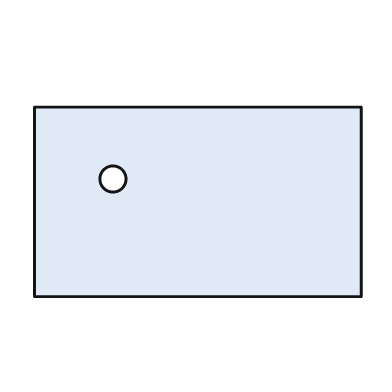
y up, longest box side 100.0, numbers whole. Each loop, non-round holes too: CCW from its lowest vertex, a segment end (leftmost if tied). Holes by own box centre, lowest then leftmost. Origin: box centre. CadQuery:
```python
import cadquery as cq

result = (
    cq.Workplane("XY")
    .moveTo(-50.0, -29.0)
    .lineTo(50.0, -29.0)
    .lineTo(50.0, 29.0)
    .lineTo(-50.0, 29.0)
    .close()
    .moveTo(-26.0, 7.0)
    .circle(4.0)
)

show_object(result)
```